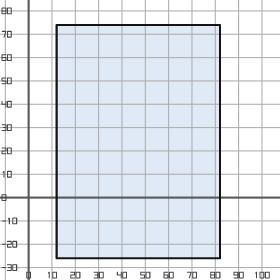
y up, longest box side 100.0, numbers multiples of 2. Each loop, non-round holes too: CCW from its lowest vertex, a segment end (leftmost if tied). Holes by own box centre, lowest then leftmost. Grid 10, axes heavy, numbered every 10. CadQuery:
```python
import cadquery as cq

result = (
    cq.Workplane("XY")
    .moveTo(12.0, -26.0)
    .lineTo(82.0, -26.0)
    .lineTo(82.0, 74.0)
    .lineTo(12.0, 74.0)
    .close()
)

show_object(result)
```